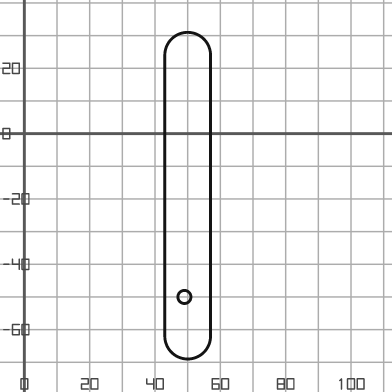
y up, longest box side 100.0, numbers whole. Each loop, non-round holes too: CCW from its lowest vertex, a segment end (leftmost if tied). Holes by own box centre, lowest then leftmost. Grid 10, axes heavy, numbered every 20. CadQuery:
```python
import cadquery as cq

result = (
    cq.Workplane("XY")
    .moveTo(43.0, -62.0)
    .threePointArc((50.0, -69.0), (57.0, -62.0))
    .lineTo(57.0, 24.0)
    .threePointArc((50.0, 31.0), (43.0, 24.0))
    .close()
    .moveTo(49.0, -50.0)
    .circle(2.0)
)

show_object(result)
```